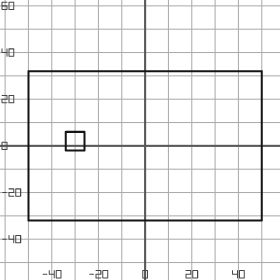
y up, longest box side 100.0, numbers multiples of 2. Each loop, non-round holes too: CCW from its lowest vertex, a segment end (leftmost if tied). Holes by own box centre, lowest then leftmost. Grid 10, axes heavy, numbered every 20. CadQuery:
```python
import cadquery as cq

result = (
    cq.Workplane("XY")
    .moveTo(-50.0, -32.0)
    .lineTo(50.0, -32.0)
    .lineTo(50.0, 32.0)
    .lineTo(-50.0, 32.0)
    .close()
    .moveTo(-34.0, -2.0)
    .lineTo(-26.0, -2.0)
    .lineTo(-26.0, 6.0)
    .lineTo(-34.0, 6.0)
    .close()
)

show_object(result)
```